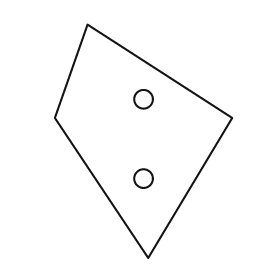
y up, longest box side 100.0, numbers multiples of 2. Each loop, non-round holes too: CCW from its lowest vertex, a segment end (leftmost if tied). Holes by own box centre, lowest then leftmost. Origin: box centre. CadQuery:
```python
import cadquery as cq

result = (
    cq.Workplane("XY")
    .moveTo(2.0, -50.0)
    .lineTo(38.0, 10.0)
    .lineTo(-24.0, 50.0)
    .lineTo(-38.0, 10.0)
    .close()
    .moveTo(0.0, -16.0)
    .circle(4.0)
    .moveTo(0.0, 18.0)
    .circle(4.0)
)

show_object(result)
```